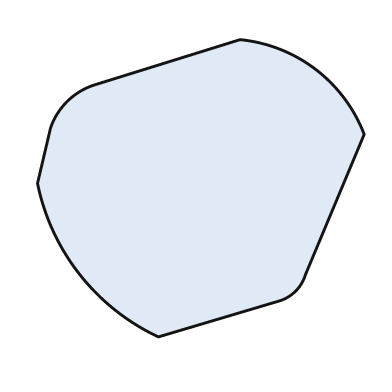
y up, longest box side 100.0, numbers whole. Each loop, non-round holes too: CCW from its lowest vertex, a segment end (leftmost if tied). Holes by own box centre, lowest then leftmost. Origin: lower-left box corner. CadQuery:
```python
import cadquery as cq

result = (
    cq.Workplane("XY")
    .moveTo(37.0, 0.0)
    .lineTo(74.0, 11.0)
    .threePointArc((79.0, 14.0), (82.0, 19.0))
    .lineTo(100.0, 62.0)
    .threePointArc((85.0, 82.0), (62.0, 91.0))
    .lineTo(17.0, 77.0)
    .threePointArc((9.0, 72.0), (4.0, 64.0))
    .lineTo(0.0, 47.0)
    .threePointArc((13.0, 19.0), (37.0, 0.0))
    .close()
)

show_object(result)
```